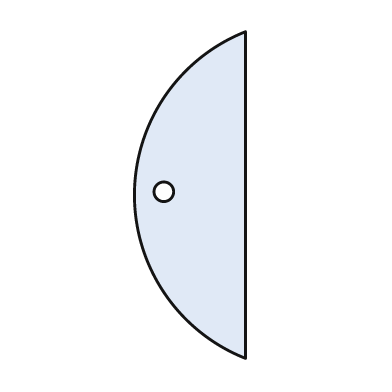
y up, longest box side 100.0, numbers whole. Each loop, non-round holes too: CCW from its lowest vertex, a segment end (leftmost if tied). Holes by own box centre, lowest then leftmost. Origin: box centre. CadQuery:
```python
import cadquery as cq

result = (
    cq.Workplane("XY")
    .moveTo(17.0, -50.0)
    .lineTo(17.0, 50.0)
    .threePointArc((-17.0, 0.0), (17.0, -50.0))
    .close()
    .moveTo(-8.0, 1.0)
    .circle(3.0)
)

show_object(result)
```